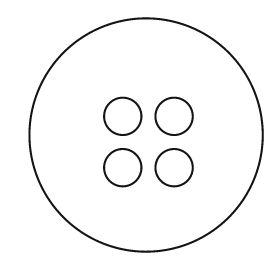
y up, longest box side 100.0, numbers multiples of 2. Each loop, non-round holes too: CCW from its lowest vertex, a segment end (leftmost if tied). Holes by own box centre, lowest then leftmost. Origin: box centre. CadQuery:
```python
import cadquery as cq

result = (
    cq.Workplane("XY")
    .moveTo(0.0, 0.0)
    .circle(50.0)
    .moveTo(-10.0, -14.0)
    .circle(8.0)
    .moveTo(12.0, -14.0)
    .circle(8.0)
    .moveTo(-10.0, 8.0)
    .circle(8.0)
    .moveTo(12.0, 8.0)
    .circle(8.0)
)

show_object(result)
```